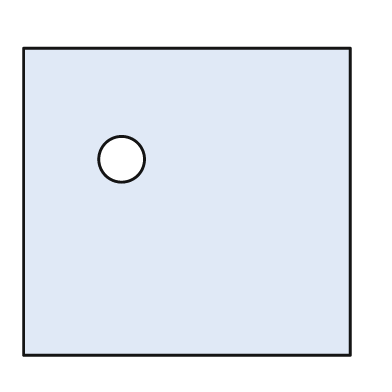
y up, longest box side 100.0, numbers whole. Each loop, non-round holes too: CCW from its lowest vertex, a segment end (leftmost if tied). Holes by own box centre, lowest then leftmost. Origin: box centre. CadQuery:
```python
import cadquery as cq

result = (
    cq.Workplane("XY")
    .moveTo(-50.0, -47.0)
    .lineTo(50.0, -47.0)
    .lineTo(50.0, 47.0)
    .lineTo(-50.0, 47.0)
    .close()
    .moveTo(-20.0, 13.0)
    .circle(7.0)
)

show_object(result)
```